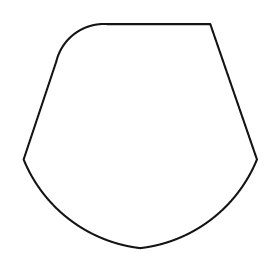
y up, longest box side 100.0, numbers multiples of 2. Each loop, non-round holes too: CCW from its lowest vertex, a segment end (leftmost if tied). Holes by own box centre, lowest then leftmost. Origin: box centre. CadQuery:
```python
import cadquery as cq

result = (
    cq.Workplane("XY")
    .moveTo(0.0, -48.0)
    .threePointArc((30.0, -36.0), (50.0, -10.0))
    .lineTo(30.0, 48.0)
    .lineTo(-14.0, 48.0)
    .threePointArc((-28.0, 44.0), (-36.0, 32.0))
    .lineTo(-50.0, -10.0)
    .threePointArc((-30.0, -36.0), (0.0, -48.0))
    .close()
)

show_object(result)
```